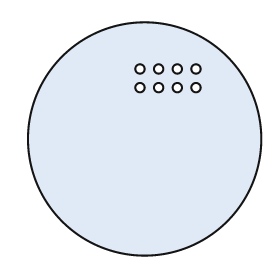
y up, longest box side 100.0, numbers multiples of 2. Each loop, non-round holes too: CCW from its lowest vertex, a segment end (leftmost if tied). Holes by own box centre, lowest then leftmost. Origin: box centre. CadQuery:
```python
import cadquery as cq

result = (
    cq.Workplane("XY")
    .moveTo(0.0, 0.0)
    .circle(50.0)
    .moveTo(-2.0, 22.0)
    .circle(2.0)
    .moveTo(6.0, 22.0)
    .circle(2.0)
    .moveTo(14.0, 22.0)
    .circle(2.0)
    .moveTo(22.0, 22.0)
    .circle(2.0)
    .moveTo(-2.0, 30.0)
    .circle(2.0)
    .moveTo(6.0, 30.0)
    .circle(2.0)
    .moveTo(14.0, 30.0)
    .circle(2.0)
    .moveTo(22.0, 30.0)
    .circle(2.0)
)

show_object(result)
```